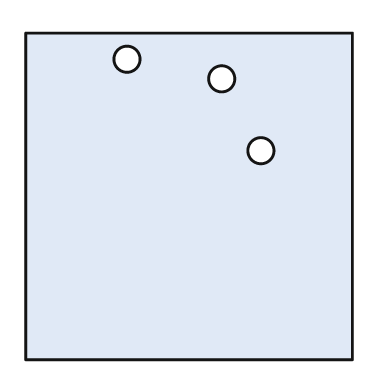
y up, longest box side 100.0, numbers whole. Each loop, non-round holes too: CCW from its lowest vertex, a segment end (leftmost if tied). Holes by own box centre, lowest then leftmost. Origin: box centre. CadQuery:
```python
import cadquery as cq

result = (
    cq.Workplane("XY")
    .moveTo(-50.0, -50.0)
    .lineTo(50.0, -50.0)
    .lineTo(50.0, 50.0)
    .lineTo(-50.0, 50.0)
    .close()
    .moveTo(22.0, 14.0)
    .circle(4.0)
    .moveTo(10.0, 36.0)
    .circle(4.0)
    .moveTo(-19.0, 42.0)
    .circle(4.0)
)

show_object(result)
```